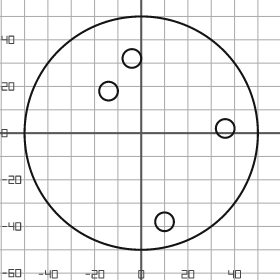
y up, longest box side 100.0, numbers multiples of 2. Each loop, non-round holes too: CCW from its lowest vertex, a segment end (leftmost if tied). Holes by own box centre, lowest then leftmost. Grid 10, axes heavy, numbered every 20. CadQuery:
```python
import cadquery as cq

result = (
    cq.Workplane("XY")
    .moveTo(0.0, 0.0)
    .circle(50.0)
    .moveTo(10.0, -38.0)
    .circle(4.0)
    .moveTo(36.0, 2.0)
    .circle(4.0)
    .moveTo(-14.0, 18.0)
    .circle(4.0)
    .moveTo(-4.0, 32.0)
    .circle(4.0)
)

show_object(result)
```